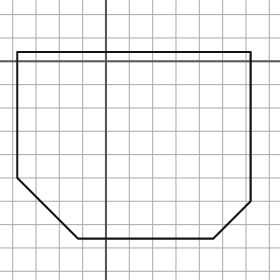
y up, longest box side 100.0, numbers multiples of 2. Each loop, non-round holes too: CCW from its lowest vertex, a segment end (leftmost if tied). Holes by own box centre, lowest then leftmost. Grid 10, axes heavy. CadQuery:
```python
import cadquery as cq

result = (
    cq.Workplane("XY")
    .moveTo(-12.0, -76.0)
    .lineTo(46.0, -76.0)
    .lineTo(62.0, -60.0)
    .lineTo(62.0, 4.0)
    .lineTo(-38.0, 4.0)
    .lineTo(-38.0, -50.0)
    .close()
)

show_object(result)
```